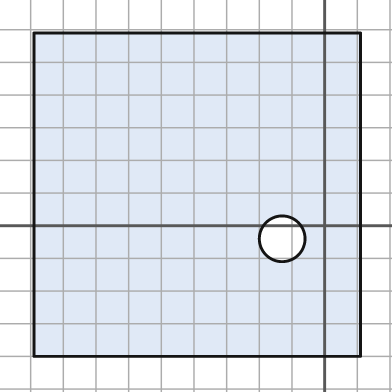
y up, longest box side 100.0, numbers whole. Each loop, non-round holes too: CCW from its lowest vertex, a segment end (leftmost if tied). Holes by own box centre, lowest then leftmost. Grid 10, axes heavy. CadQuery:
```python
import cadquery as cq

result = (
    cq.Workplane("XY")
    .moveTo(-89.0, -40.0)
    .lineTo(11.0, -40.0)
    .lineTo(11.0, 59.0)
    .lineTo(-89.0, 59.0)
    .close()
    .moveTo(-13.0, -4.0)
    .circle(7.0)
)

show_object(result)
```